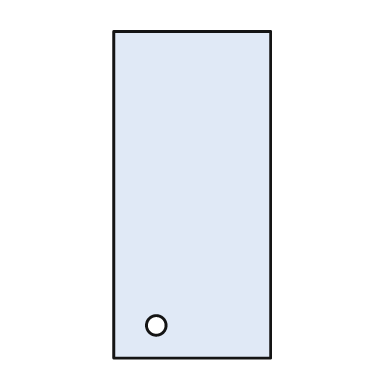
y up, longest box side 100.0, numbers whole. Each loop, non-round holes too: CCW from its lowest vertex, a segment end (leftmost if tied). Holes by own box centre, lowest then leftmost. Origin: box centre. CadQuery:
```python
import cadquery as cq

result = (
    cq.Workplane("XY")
    .moveTo(-24.0, -50.0)
    .lineTo(24.0, -50.0)
    .lineTo(24.0, 50.0)
    .lineTo(-24.0, 50.0)
    .close()
    .moveTo(-11.0, -40.0)
    .circle(3.0)
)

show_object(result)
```